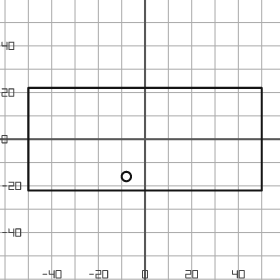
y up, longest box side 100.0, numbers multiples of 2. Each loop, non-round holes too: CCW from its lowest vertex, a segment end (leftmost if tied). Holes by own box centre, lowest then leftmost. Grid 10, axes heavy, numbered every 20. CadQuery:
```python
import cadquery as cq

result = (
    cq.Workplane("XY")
    .moveTo(-50.0, -22.0)
    .lineTo(50.0, -22.0)
    .lineTo(50.0, 22.0)
    .lineTo(-50.0, 22.0)
    .close()
    .moveTo(-8.0, -16.0)
    .circle(2.0)
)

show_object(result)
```